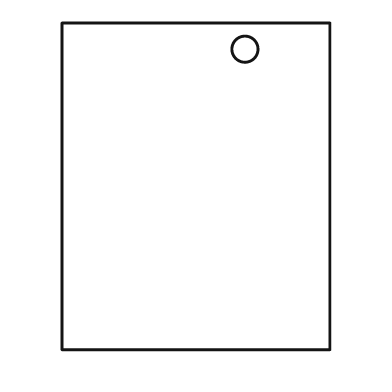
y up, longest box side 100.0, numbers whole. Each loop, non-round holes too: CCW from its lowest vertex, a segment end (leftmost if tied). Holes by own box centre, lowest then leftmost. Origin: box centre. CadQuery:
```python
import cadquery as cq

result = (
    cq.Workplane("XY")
    .moveTo(-41.0, -50.0)
    .lineTo(41.0, -50.0)
    .lineTo(41.0, 50.0)
    .lineTo(-41.0, 50.0)
    .close()
    .moveTo(15.0, 42.0)
    .circle(4.0)
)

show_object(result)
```